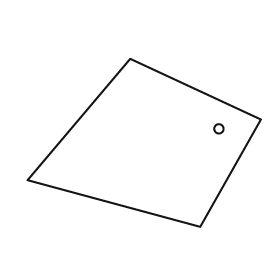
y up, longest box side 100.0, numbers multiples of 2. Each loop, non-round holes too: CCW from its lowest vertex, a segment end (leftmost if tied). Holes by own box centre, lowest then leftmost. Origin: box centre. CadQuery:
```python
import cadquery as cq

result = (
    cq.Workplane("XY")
    .moveTo(24.0, -36.0)
    .lineTo(50.0, 10.0)
    .lineTo(-6.0, 36.0)
    .lineTo(-50.0, -16.0)
    .close()
    .moveTo(32.0, 6.0)
    .circle(2.0)
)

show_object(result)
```